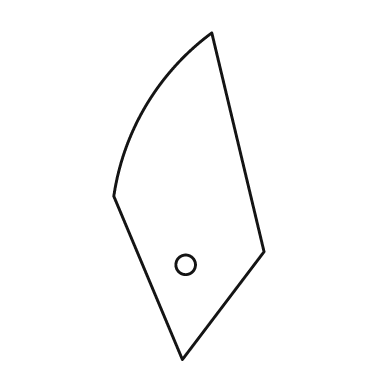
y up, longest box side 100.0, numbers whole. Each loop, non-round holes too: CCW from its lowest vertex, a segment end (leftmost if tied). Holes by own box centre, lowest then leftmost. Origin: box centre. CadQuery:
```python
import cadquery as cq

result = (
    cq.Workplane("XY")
    .moveTo(-2.0, -50.0)
    .lineTo(23.0, -17.0)
    .lineTo(7.0, 50.0)
    .threePointArc((-13.0, 28.0), (-23.0, 0.0))
    .close()
    .moveTo(-1.0, -21.0)
    .circle(3.0)
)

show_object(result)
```